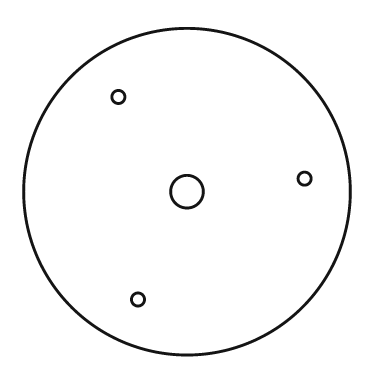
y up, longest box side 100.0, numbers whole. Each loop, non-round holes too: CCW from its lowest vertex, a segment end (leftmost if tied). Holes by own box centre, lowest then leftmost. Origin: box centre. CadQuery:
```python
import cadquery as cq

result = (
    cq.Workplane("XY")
    .moveTo(0.0, 0.0)
    .circle(50.0)
    .moveTo(-15.0, -33.0)
    .circle(2.0)
    .moveTo(0.0, 0.0)
    .circle(5.0)
    .moveTo(36.0, 4.0)
    .circle(2.0)
    .moveTo(-21.0, 29.0)
    .circle(2.0)
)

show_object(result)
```